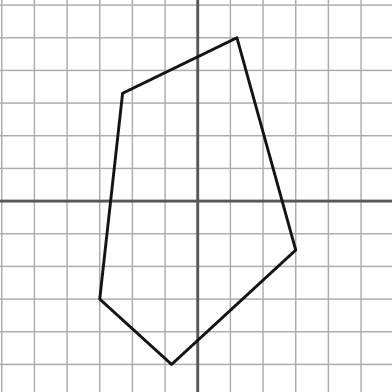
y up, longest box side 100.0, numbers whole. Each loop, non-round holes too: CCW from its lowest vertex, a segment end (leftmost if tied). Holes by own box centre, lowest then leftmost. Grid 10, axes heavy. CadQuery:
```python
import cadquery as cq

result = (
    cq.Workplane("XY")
    .moveTo(-8.0, -50.0)
    .lineTo(30.0, -15.0)
    .lineTo(12.0, 50.0)
    .lineTo(-23.0, 33.0)
    .lineTo(-30.0, -30.0)
    .close()
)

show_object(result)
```